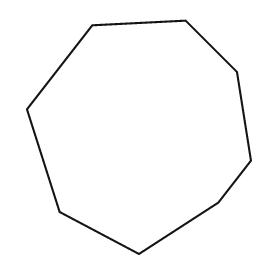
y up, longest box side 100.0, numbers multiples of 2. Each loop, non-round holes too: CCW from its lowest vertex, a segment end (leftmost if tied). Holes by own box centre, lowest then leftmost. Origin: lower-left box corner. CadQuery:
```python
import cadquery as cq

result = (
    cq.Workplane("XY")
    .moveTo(48.0, 0.0)
    .lineTo(82.0, 22.0)
    .lineTo(96.0, 40.0)
    .lineTo(90.0, 78.0)
    .lineTo(68.0, 100.0)
    .lineTo(28.0, 98.0)
    .lineTo(0.0, 62.0)
    .lineTo(14.0, 18.0)
    .close()
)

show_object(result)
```